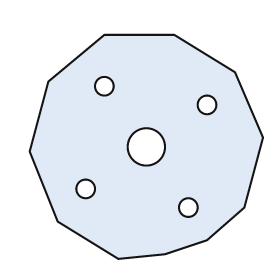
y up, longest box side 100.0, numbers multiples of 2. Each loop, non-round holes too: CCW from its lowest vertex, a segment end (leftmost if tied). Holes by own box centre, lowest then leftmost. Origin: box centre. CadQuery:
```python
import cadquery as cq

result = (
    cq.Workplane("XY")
    .moveTo(-12.0, -48.0)
    .lineTo(8.0, -46.0)
    .lineTo(26.0, -40.0)
    .lineTo(42.0, -26.0)
    .lineTo(50.0, 4.0)
    .lineTo(38.0, 32.0)
    .lineTo(12.0, 48.0)
    .lineTo(-18.0, 48.0)
    .lineTo(-42.0, 28.0)
    .lineTo(-50.0, -2.0)
    .lineTo(-38.0, -32.0)
    .close()
    .moveTo(18.0, -26.0)
    .circle(4.0)
    .moveTo(-26.0, -18.0)
    .circle(4.0)
    .moveTo(0.0, 0.0)
    .circle(8.0)
    .moveTo(26.0, 18.0)
    .circle(4.0)
    .moveTo(-18.0, 26.0)
    .circle(4.0)
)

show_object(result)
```